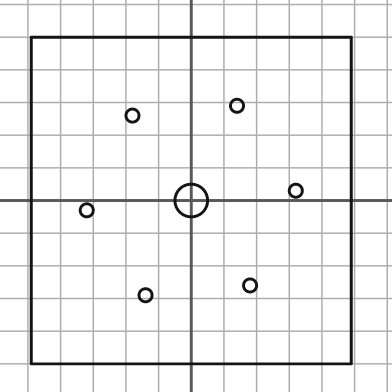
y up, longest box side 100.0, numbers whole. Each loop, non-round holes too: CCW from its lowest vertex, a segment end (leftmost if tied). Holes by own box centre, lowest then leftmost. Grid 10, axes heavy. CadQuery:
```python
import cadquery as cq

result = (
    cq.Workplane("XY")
    .moveTo(-49.0, -50.0)
    .lineTo(49.0, -50.0)
    .lineTo(49.0, 50.0)
    .lineTo(-49.0, 50.0)
    .close()
    .moveTo(-14.0, -29.0)
    .circle(2.0)
    .moveTo(18.0, -26.0)
    .circle(2.0)
    .moveTo(-32.0, -3.0)
    .circle(2.0)
    .moveTo(0.0, 0.0)
    .circle(5.0)
    .moveTo(32.0, 3.0)
    .circle(2.0)
    .moveTo(-18.0, 26.0)
    .circle(2.0)
    .moveTo(14.0, 29.0)
    .circle(2.0)
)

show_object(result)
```